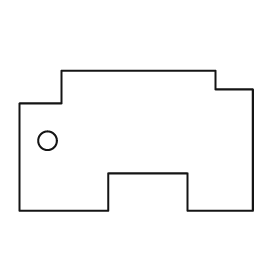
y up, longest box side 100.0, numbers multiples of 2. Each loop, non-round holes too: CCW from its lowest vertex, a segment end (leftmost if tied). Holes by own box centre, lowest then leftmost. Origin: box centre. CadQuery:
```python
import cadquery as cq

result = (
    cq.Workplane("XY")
    .moveTo(-50.0, -30.0)
    .lineTo(-12.0, -30.0)
    .lineTo(-12.0, -14.0)
    .lineTo(22.0, -14.0)
    .lineTo(22.0, -30.0)
    .lineTo(50.0, -30.0)
    .lineTo(50.0, 22.0)
    .lineTo(34.0, 22.0)
    .lineTo(34.0, 30.0)
    .lineTo(-32.0, 30.0)
    .lineTo(-32.0, 16.0)
    .lineTo(-50.0, 16.0)
    .close()
    .moveTo(-38.0, 0.0)
    .circle(4.0)
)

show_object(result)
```